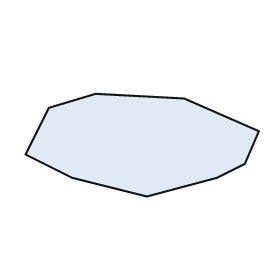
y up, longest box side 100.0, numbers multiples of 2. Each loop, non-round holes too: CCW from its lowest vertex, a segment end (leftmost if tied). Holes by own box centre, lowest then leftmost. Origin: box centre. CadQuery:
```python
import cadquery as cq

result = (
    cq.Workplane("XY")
    .moveTo(2.0, -22.0)
    .lineTo(32.0, -14.0)
    .lineTo(44.0, -8.0)
    .lineTo(50.0, 6.0)
    .lineTo(18.0, 20.0)
    .lineTo(-20.0, 22.0)
    .lineTo(-40.0, 16.0)
    .lineTo(-50.0, -4.0)
    .lineTo(-30.0, -14.0)
    .close()
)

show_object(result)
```